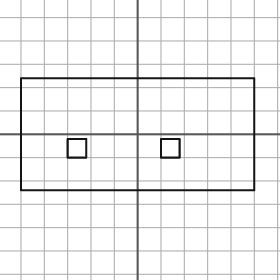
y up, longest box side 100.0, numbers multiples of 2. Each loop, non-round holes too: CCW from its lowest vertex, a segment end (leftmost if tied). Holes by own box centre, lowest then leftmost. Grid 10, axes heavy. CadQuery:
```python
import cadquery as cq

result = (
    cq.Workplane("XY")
    .moveTo(-50.0, -24.0)
    .lineTo(50.0, -24.0)
    .lineTo(50.0, 24.0)
    .lineTo(-50.0, 24.0)
    .close()
    .moveTo(-30.0, -10.0)
    .lineTo(-22.0, -10.0)
    .lineTo(-22.0, -2.0)
    .lineTo(-30.0, -2.0)
    .close()
    .moveTo(10.0, -10.0)
    .lineTo(18.0, -10.0)
    .lineTo(18.0, -2.0)
    .lineTo(10.0, -2.0)
    .close()
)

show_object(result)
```